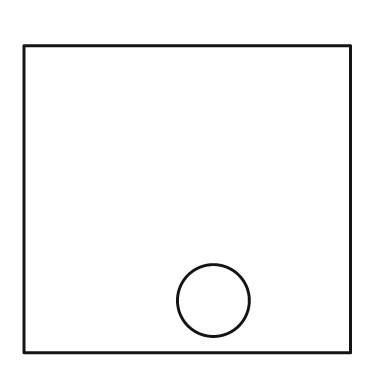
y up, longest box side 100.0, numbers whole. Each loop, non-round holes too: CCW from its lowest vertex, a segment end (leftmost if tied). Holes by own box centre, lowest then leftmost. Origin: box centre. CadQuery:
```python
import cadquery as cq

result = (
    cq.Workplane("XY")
    .moveTo(-50.0, -47.0)
    .lineTo(50.0, -47.0)
    .lineTo(50.0, 47.0)
    .lineTo(-50.0, 47.0)
    .close()
    .moveTo(8.0, -31.0)
    .circle(11.0)
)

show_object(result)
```